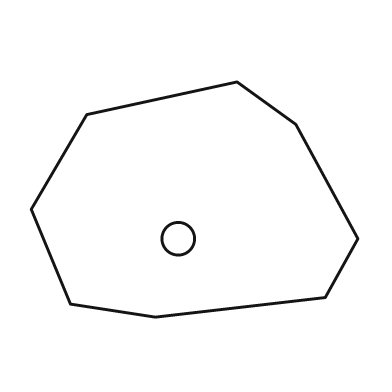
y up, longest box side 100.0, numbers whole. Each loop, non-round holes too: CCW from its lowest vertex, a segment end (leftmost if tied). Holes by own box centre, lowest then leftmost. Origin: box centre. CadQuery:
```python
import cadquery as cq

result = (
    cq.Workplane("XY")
    .moveTo(-12.0, -36.0)
    .lineTo(40.0, -30.0)
    .lineTo(50.0, -12.0)
    .lineTo(31.0, 23.0)
    .lineTo(13.0, 36.0)
    .lineTo(-33.0, 26.0)
    .lineTo(-50.0, -3.0)
    .lineTo(-38.0, -32.0)
    .close()
    .moveTo(-5.0, -12.0)
    .circle(5.0)
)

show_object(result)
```